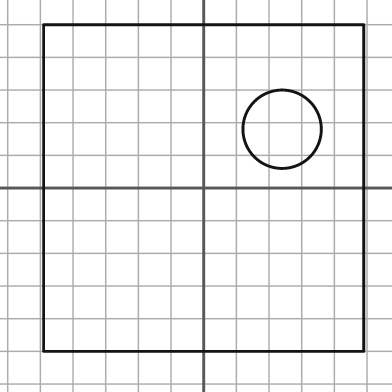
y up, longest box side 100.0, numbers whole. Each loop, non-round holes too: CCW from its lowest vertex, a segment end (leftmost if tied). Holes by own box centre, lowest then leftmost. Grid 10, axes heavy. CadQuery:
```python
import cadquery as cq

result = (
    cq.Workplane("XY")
    .moveTo(-49.0, -50.0)
    .lineTo(49.0, -50.0)
    .lineTo(49.0, 50.0)
    .lineTo(-49.0, 50.0)
    .close()
    .moveTo(24.0, 18.0)
    .circle(12.0)
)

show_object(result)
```